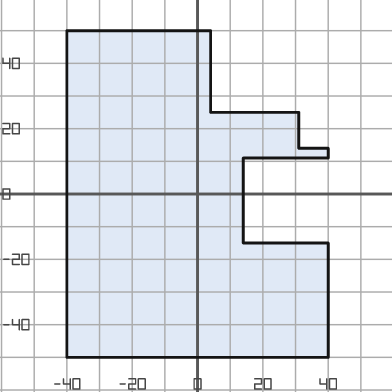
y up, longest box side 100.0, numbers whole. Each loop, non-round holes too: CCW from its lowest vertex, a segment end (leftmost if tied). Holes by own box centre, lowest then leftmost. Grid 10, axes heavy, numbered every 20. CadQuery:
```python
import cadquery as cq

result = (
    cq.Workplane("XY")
    .moveTo(-40.0, -50.0)
    .lineTo(40.0, -50.0)
    .lineTo(40.0, -15.0)
    .lineTo(14.0, -15.0)
    .lineTo(14.0, 11.0)
    .lineTo(40.0, 11.0)
    .lineTo(40.0, 14.0)
    .lineTo(31.0, 14.0)
    .lineTo(31.0, 25.0)
    .lineTo(4.0, 25.0)
    .lineTo(4.0, 50.0)
    .lineTo(-40.0, 50.0)
    .close()
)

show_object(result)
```